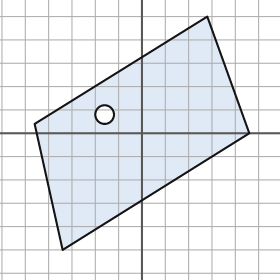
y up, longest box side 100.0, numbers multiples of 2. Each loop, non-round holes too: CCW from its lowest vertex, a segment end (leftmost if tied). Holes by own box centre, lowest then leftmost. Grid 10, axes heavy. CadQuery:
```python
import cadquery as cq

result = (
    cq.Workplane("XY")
    .moveTo(-34.0, -50.0)
    .lineTo(46.0, 0.0)
    .lineTo(28.0, 50.0)
    .lineTo(-46.0, 4.0)
    .close()
    .moveTo(-16.0, 8.0)
    .circle(4.0)
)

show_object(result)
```